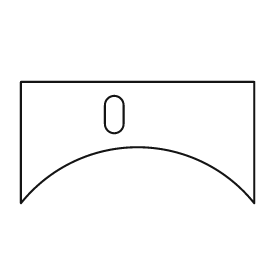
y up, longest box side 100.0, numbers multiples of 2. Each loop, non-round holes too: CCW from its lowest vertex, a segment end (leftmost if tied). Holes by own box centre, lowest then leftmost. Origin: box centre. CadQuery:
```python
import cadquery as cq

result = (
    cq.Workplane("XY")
    .moveTo(-50.0, -26.0)
    .threePointArc((0.0, -2.0), (50.0, -26.0))
    .lineTo(50.0, 26.0)
    .lineTo(-50.0, 26.0)
    .close()
    .moveTo(-14.0, 8.0)
    .threePointArc((-10.0, 4.0), (-6.0, 8.0))
    .lineTo(-6.0, 16.0)
    .threePointArc((-10.0, 20.0), (-14.0, 16.0))
    .close()
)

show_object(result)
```